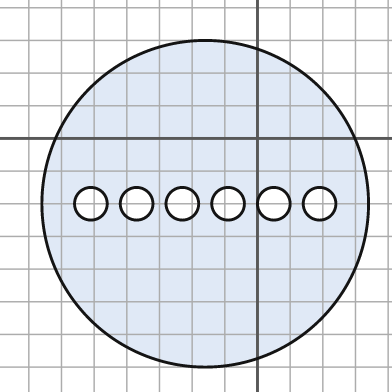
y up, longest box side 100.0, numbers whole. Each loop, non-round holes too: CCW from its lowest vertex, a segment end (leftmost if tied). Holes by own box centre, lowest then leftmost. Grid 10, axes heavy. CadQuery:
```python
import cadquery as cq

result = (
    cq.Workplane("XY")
    .moveTo(-16.0, -20.0)
    .circle(50.0)
    .moveTo(-51.0, -20.0)
    .circle(5.0)
    .moveTo(-37.0, -20.0)
    .circle(5.0)
    .moveTo(-23.0, -20.0)
    .circle(5.0)
    .moveTo(-9.0, -20.0)
    .circle(5.0)
    .moveTo(5.0, -20.0)
    .circle(5.0)
    .moveTo(19.0, -20.0)
    .circle(5.0)
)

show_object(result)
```